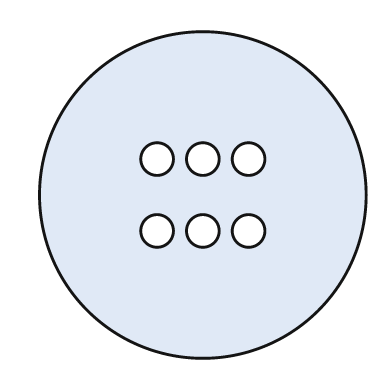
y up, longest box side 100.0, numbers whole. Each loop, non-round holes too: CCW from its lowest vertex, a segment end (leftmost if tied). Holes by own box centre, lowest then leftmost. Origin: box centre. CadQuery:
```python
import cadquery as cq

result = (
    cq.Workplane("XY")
    .moveTo(0.0, 0.0)
    .circle(50.0)
    .moveTo(-14.0, -11.0)
    .circle(5.0)
    .moveTo(0.0, -11.0)
    .circle(5.0)
    .moveTo(14.0, -11.0)
    .circle(5.0)
    .moveTo(-14.0, 11.0)
    .circle(5.0)
    .moveTo(0.0, 11.0)
    .circle(5.0)
    .moveTo(14.0, 11.0)
    .circle(5.0)
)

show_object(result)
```